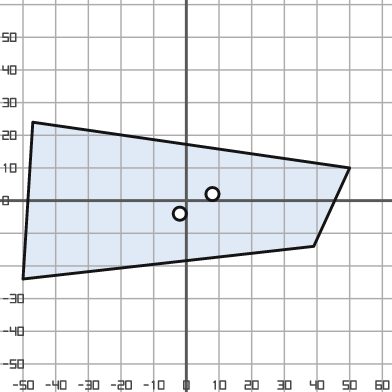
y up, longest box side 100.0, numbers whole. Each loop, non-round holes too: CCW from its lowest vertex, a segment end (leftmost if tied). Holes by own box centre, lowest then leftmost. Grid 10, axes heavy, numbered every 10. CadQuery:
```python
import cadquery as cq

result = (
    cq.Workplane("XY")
    .moveTo(-50.0, -24.0)
    .lineTo(39.0, -14.0)
    .lineTo(50.0, 10.0)
    .lineTo(-47.0, 24.0)
    .close()
    .moveTo(-2.0, -4.0)
    .circle(2.0)
    .moveTo(8.0, 2.0)
    .circle(2.0)
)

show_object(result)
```